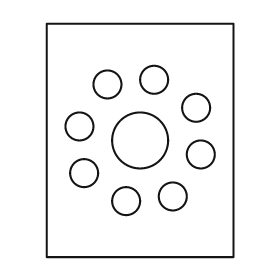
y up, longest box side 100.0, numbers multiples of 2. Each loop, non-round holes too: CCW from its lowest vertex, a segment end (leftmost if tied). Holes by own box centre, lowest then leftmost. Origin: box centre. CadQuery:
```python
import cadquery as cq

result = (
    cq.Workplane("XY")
    .moveTo(-40.0, -50.0)
    .lineTo(40.0, -50.0)
    .lineTo(40.0, 50.0)
    .lineTo(-40.0, 50.0)
    .close()
    .moveTo(-6.0, -26.0)
    .circle(6.0)
    .moveTo(14.0, -24.0)
    .circle(6.0)
    .moveTo(-24.0, -14.0)
    .circle(6.0)
    .moveTo(26.0, -6.0)
    .circle(6.0)
    .moveTo(0.0, 0.0)
    .circle(12.0)
    .moveTo(-26.0, 6.0)
    .circle(6.0)
    .moveTo(24.0, 14.0)
    .circle(6.0)
    .moveTo(-14.0, 24.0)
    .circle(6.0)
    .moveTo(6.0, 26.0)
    .circle(6.0)
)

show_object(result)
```